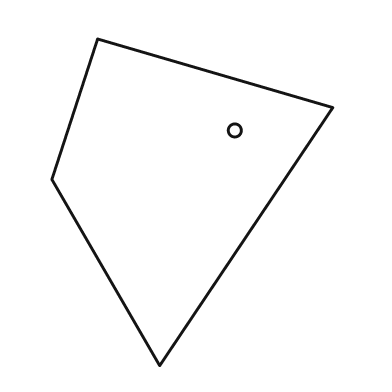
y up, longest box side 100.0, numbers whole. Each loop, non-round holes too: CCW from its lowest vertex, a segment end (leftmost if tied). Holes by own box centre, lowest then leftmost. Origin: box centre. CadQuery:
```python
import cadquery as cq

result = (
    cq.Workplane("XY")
    .moveTo(-10.0, -50.0)
    .lineTo(43.0, 29.0)
    .lineTo(-29.0, 50.0)
    .lineTo(-43.0, 7.0)
    .close()
    .moveTo(13.0, 22.0)
    .circle(2.0)
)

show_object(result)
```